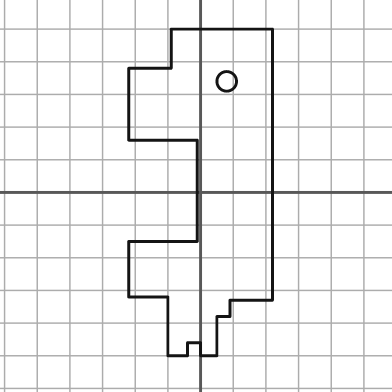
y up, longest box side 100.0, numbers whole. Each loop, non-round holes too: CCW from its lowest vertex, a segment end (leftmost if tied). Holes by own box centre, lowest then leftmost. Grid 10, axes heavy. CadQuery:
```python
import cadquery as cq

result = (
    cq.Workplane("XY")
    .moveTo(-10.0, -50.0)
    .lineTo(-4.0, -50.0)
    .lineTo(-4.0, -46.0)
    .lineTo(0.0, -46.0)
    .lineTo(0.0, -50.0)
    .lineTo(5.0, -50.0)
    .lineTo(5.0, -38.0)
    .lineTo(9.0, -38.0)
    .lineTo(9.0, -33.0)
    .lineTo(22.0, -33.0)
    .lineTo(22.0, 50.0)
    .lineTo(-9.0, 50.0)
    .lineTo(-9.0, 38.0)
    .lineTo(-22.0, 38.0)
    .lineTo(-22.0, 16.0)
    .lineTo(-1.0, 16.0)
    .lineTo(-1.0, -15.0)
    .lineTo(-22.0, -15.0)
    .lineTo(-22.0, -32.0)
    .lineTo(-10.0, -32.0)
    .close()
    .moveTo(8.0, 34.0)
    .circle(3.0)
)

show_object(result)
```